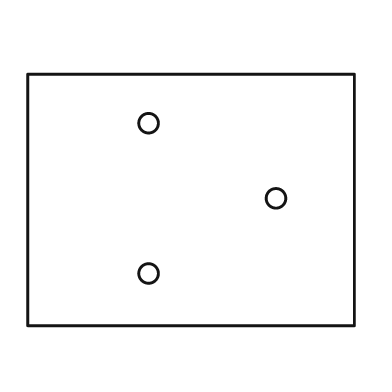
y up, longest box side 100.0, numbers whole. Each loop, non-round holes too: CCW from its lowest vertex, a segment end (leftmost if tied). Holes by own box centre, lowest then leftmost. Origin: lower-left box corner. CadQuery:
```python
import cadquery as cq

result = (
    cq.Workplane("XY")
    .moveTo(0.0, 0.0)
    .lineTo(100.0, 0.0)
    .lineTo(100.0, 77.0)
    .lineTo(0.0, 77.0)
    .close()
    .moveTo(37.0, 16.0)
    .circle(3.0)
    .moveTo(76.0, 39.0)
    .circle(3.0)
    .moveTo(37.0, 62.0)
    .circle(3.0)
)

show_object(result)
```